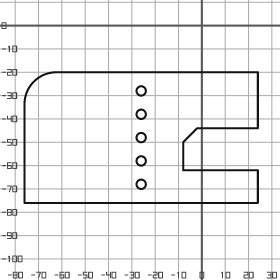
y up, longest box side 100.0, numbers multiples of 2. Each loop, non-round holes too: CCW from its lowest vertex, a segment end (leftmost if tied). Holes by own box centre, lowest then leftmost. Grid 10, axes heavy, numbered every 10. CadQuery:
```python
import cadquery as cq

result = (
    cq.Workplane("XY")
    .moveTo(-76.0, -76.0)
    .lineTo(24.0, -76.0)
    .lineTo(24.0, -62.0)
    .lineTo(-8.0, -62.0)
    .lineTo(-8.0, -50.0)
    .lineTo(-2.0, -44.0)
    .lineTo(24.0, -44.0)
    .lineTo(24.0, -20.0)
    .lineTo(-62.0, -20.0)
    .threePointArc((-72.0, -24.0), (-76.0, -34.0))
    .close()
    .moveTo(-26.0, -68.0)
    .circle(2.0)
    .moveTo(-26.0, -58.0)
    .circle(2.0)
    .moveTo(-26.0, -48.0)
    .circle(2.0)
    .moveTo(-26.0, -38.0)
    .circle(2.0)
    .moveTo(-26.0, -28.0)
    .circle(2.0)
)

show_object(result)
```